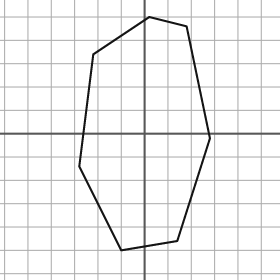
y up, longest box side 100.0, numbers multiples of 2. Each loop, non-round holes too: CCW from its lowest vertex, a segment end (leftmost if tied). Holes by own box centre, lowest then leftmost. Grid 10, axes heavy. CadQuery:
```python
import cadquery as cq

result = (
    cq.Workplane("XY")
    .moveTo(-10.0, -50.0)
    .lineTo(14.0, -46.0)
    .lineTo(28.0, -2.0)
    .lineTo(18.0, 46.0)
    .lineTo(2.0, 50.0)
    .lineTo(-22.0, 34.0)
    .lineTo(-28.0, -14.0)
    .close()
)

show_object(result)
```